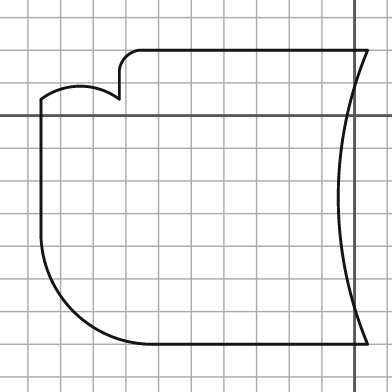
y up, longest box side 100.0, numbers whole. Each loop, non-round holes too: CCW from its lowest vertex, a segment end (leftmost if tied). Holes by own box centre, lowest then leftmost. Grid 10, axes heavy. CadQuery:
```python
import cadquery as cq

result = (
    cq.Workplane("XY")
    .moveTo(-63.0, -70.0)
    .lineTo(4.0, -70.0)
    .threePointArc((-5.0, -25.0), (4.0, 20.0))
    .lineTo(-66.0, 20.0)
    .threePointArc((-70.0, 18.0), (-72.0, 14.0))
    .lineTo(-72.0, 5.0)
    .threePointArc((-84.0, 9.0), (-96.0, 5.0))
    .lineTo(-96.0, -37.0)
    .threePointArc((-86.0, -60.0), (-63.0, -70.0))
    .close()
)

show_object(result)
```